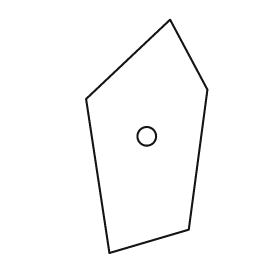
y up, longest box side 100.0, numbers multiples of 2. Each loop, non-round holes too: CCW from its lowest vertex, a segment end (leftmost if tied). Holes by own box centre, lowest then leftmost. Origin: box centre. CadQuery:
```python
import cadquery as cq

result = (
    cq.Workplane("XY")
    .moveTo(-16.0, -50.0)
    .lineTo(18.0, -40.0)
    .lineTo(26.0, 20.0)
    .lineTo(10.0, 50.0)
    .lineTo(-26.0, 16.0)
    .close()
    .moveTo(0.0, 0.0)
    .circle(4.0)
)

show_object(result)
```